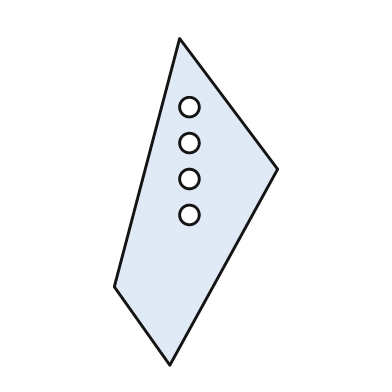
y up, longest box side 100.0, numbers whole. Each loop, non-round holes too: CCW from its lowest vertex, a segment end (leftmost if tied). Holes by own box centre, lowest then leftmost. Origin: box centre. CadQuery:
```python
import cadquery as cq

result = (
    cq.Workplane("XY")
    .moveTo(-8.0, -50.0)
    .lineTo(25.0, 10.0)
    .lineTo(-5.0, 50.0)
    .lineTo(-25.0, -26.0)
    .close()
    .moveTo(-2.0, -4.0)
    .circle(3.0)
    .moveTo(-2.0, 7.0)
    .circle(3.0)
    .moveTo(-2.0, 18.0)
    .circle(3.0)
    .moveTo(-2.0, 29.0)
    .circle(3.0)
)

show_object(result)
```